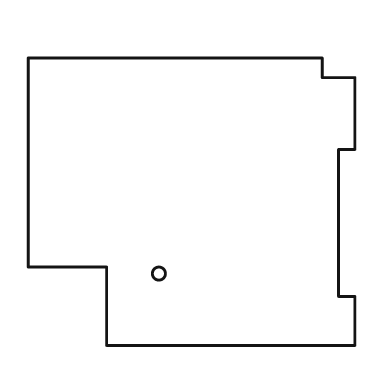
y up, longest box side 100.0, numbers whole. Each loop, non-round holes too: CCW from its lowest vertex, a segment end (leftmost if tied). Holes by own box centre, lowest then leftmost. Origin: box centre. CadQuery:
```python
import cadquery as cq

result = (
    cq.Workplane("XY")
    .moveTo(-26.0, -44.0)
    .lineTo(50.0, -44.0)
    .lineTo(50.0, -29.0)
    .lineTo(45.0, -29.0)
    .lineTo(45.0, 16.0)
    .lineTo(50.0, 16.0)
    .lineTo(50.0, 38.0)
    .lineTo(40.0, 38.0)
    .lineTo(40.0, 44.0)
    .lineTo(-50.0, 44.0)
    .lineTo(-50.0, -20.0)
    .lineTo(-26.0, -20.0)
    .close()
    .moveTo(-10.0, -22.0)
    .circle(2.0)
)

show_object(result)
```